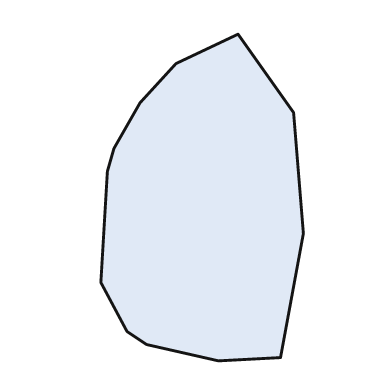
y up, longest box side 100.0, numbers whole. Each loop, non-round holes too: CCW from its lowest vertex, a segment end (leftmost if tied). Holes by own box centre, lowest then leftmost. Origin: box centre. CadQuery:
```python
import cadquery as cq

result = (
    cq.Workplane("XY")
    .moveTo(5.0, -50.0)
    .lineTo(24.0, -49.0)
    .lineTo(31.0, -11.0)
    .lineTo(28.0, 26.0)
    .lineTo(11.0, 50.0)
    .lineTo(-8.0, 41.0)
    .lineTo(-19.0, 29.0)
    .lineTo(-27.0, 15.0)
    .lineTo(-29.0, 8.0)
    .lineTo(-31.0, -26.0)
    .lineTo(-23.0, -41.0)
    .lineTo(-17.0, -45.0)
    .close()
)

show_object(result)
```